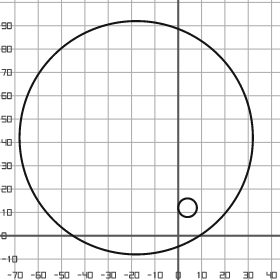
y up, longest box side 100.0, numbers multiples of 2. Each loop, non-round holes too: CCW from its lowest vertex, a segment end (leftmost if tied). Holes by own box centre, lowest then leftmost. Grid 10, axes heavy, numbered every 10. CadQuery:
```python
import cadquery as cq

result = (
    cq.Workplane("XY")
    .moveTo(-18.0, 42.0)
    .circle(50.0)
    .moveTo(4.0, 12.0)
    .circle(4.0)
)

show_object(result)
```